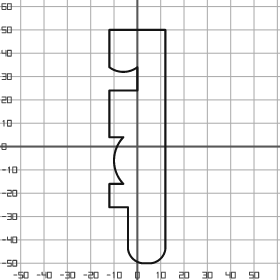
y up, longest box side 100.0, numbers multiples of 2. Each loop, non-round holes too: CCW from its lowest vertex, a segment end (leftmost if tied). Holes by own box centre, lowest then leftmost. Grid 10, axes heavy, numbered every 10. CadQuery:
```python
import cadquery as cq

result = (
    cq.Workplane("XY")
    .moveTo(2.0, -50.0)
    .lineTo(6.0, -50.0)
    .threePointArc((10.0, -48.0), (12.0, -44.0))
    .lineTo(12.0, 50.0)
    .lineTo(-12.0, 50.0)
    .lineTo(-12.0, 34.0)
    .threePointArc((-6.0, 32.0), (0.0, 34.0))
    .lineTo(0.0, 24.0)
    .lineTo(-12.0, 24.0)
    .lineTo(-12.0, 4.0)
    .lineTo(-6.0, 4.0)
    .threePointArc((-10.0, -6.0), (-6.0, -16.0))
    .lineTo(-12.0, -16.0)
    .lineTo(-12.0, -26.0)
    .lineTo(-4.0, -26.0)
    .lineTo(-4.0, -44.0)
    .threePointArc((-2.0, -48.0), (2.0, -50.0))
    .close()
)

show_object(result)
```